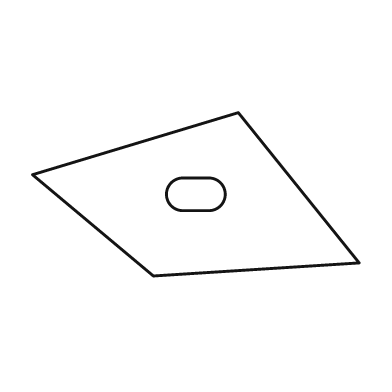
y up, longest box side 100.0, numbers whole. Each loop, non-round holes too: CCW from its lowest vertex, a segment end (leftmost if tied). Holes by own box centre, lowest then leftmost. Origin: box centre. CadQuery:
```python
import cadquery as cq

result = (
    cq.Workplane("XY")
    .moveTo(-13.0, -25.0)
    .lineTo(50.0, -21.0)
    .lineTo(13.0, 25.0)
    .lineTo(-50.0, 6.0)
    .close()
    .moveTo(-4.0, -5.0)
    .lineTo(4.0, -5.0)
    .threePointArc((9.0, 0.0), (4.0, 5.0))
    .lineTo(-4.0, 5.0)
    .threePointArc((-9.0, 0.0), (-4.0, -5.0))
    .close()
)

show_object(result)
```